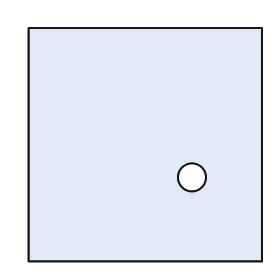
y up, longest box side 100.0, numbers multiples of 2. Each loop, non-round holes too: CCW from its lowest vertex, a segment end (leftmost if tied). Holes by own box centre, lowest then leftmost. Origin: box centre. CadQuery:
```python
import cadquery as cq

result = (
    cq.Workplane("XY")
    .moveTo(-50.0, -50.0)
    .lineTo(50.0, -50.0)
    .lineTo(50.0, 50.0)
    .lineTo(-50.0, 50.0)
    .close()
    .moveTo(20.0, -14.0)
    .circle(6.0)
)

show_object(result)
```